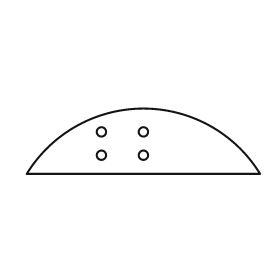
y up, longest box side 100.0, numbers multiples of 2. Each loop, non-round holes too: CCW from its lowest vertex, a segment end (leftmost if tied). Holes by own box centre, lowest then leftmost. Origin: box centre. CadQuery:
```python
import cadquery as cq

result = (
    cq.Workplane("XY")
    .moveTo(-50.0, -14.0)
    .lineTo(50.0, -14.0)
    .threePointArc((0.0, 14.0), (-50.0, -14.0))
    .close()
    .moveTo(-18.0, -6.0)
    .circle(2.0)
    .moveTo(0.0, -6.0)
    .circle(2.0)
    .moveTo(-18.0, 4.0)
    .circle(2.0)
    .moveTo(0.0, 4.0)
    .circle(2.0)
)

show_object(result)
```